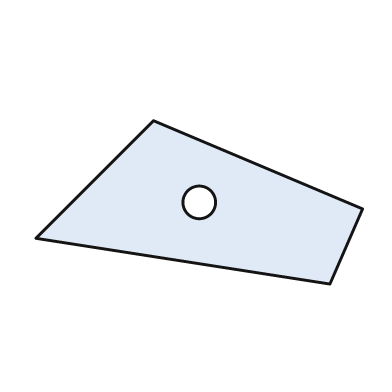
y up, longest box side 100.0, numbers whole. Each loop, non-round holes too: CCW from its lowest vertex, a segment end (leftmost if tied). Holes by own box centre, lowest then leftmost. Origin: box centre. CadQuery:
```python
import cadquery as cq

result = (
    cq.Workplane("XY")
    .moveTo(40.0, -25.0)
    .lineTo(50.0, -2.0)
    .lineTo(-14.0, 25.0)
    .lineTo(-50.0, -11.0)
    .close()
    .moveTo(0.0, 0.0)
    .circle(5.0)
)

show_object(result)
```